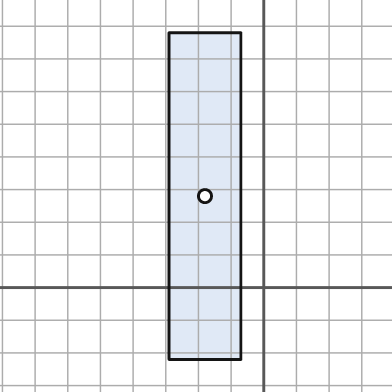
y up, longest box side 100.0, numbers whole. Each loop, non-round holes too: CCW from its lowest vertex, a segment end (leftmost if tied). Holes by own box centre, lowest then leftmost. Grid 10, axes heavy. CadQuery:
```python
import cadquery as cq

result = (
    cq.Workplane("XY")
    .moveTo(-29.0, -22.0)
    .lineTo(-7.0, -22.0)
    .lineTo(-7.0, 78.0)
    .lineTo(-29.0, 78.0)
    .close()
    .moveTo(-18.0, 28.0)
    .circle(2.0)
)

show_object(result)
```